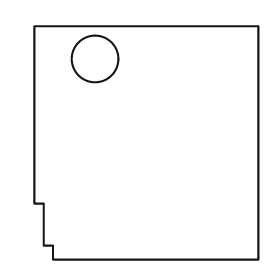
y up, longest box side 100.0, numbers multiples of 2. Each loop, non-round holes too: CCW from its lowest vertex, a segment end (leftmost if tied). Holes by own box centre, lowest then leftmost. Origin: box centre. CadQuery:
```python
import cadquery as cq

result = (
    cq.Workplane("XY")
    .moveTo(-40.0, -50.0)
    .lineTo(48.0, -50.0)
    .lineTo(48.0, 50.0)
    .lineTo(-48.0, 50.0)
    .lineTo(-48.0, -26.0)
    .lineTo(-44.0, -26.0)
    .lineTo(-44.0, -44.0)
    .lineTo(-40.0, -44.0)
    .close()
    .moveTo(-22.0, 36.0)
    .circle(10.0)
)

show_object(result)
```